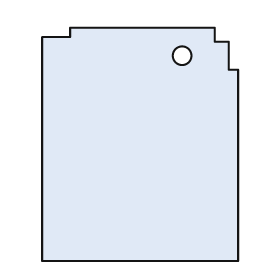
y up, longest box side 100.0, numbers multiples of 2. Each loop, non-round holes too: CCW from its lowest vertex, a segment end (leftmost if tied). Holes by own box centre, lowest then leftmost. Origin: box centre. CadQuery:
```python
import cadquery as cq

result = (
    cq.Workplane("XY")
    .moveTo(-42.0, -50.0)
    .lineTo(42.0, -50.0)
    .lineTo(42.0, 32.0)
    .lineTo(38.0, 32.0)
    .lineTo(38.0, 44.0)
    .lineTo(32.0, 44.0)
    .lineTo(32.0, 50.0)
    .lineTo(-30.0, 50.0)
    .lineTo(-30.0, 46.0)
    .lineTo(-42.0, 46.0)
    .close()
    .moveTo(18.0, 38.0)
    .circle(4.0)
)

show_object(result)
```